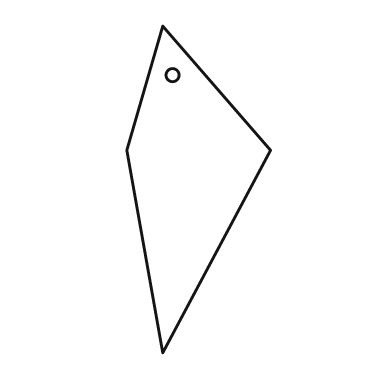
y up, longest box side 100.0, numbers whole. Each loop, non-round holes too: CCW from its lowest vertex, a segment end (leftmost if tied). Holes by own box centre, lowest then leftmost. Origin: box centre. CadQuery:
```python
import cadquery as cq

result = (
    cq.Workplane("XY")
    .moveTo(-11.0, -50.0)
    .lineTo(22.0, 12.0)
    .lineTo(-11.0, 50.0)
    .lineTo(-22.0, 12.0)
    .close()
    .moveTo(-8.0, 35.0)
    .circle(2.0)
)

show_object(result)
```